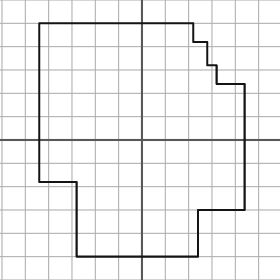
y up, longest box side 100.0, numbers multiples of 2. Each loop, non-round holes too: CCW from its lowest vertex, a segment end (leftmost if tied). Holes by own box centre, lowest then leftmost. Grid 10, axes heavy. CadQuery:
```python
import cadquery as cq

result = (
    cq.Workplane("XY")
    .moveTo(-28.0, -50.0)
    .lineTo(24.0, -50.0)
    .lineTo(24.0, -30.0)
    .lineTo(44.0, -30.0)
    .lineTo(44.0, 24.0)
    .lineTo(32.0, 24.0)
    .lineTo(32.0, 32.0)
    .lineTo(28.0, 32.0)
    .lineTo(28.0, 42.0)
    .lineTo(22.0, 42.0)
    .lineTo(22.0, 50.0)
    .lineTo(-44.0, 50.0)
    .lineTo(-44.0, -18.0)
    .lineTo(-28.0, -18.0)
    .close()
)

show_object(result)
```